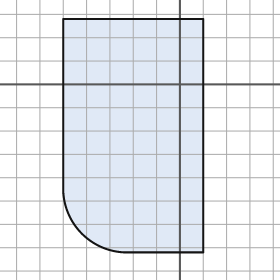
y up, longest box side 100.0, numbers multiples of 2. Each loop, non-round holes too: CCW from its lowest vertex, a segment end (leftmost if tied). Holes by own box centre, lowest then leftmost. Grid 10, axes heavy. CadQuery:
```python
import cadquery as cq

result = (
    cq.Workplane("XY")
    .moveTo(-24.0, -72.0)
    .lineTo(10.0, -72.0)
    .lineTo(10.0, 28.0)
    .lineTo(-50.0, 28.0)
    .lineTo(-50.0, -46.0)
    .threePointArc((-42.0, -64.0), (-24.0, -72.0))
    .close()
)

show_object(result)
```